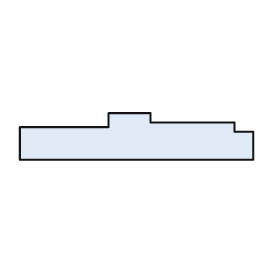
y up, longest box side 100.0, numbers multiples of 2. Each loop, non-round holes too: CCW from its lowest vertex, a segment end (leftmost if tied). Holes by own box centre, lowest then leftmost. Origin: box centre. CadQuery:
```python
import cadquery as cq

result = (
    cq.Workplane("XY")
    .moveTo(-50.0, -10.0)
    .lineTo(50.0, -10.0)
    .lineTo(50.0, 2.0)
    .lineTo(42.0, 2.0)
    .lineTo(42.0, 6.0)
    .lineTo(6.0, 6.0)
    .lineTo(6.0, 10.0)
    .lineTo(-12.0, 10.0)
    .lineTo(-12.0, 4.0)
    .lineTo(-50.0, 4.0)
    .close()
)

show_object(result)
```